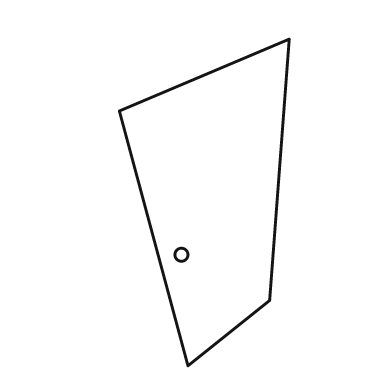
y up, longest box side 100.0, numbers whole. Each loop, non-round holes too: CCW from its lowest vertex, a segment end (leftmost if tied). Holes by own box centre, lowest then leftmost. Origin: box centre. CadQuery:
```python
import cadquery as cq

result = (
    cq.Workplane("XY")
    .moveTo(-5.0, -50.0)
    .lineTo(20.0, -30.0)
    .lineTo(26.0, 50.0)
    .lineTo(-26.0, 28.0)
    .close()
    .moveTo(-7.0, -16.0)
    .circle(2.0)
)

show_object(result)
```